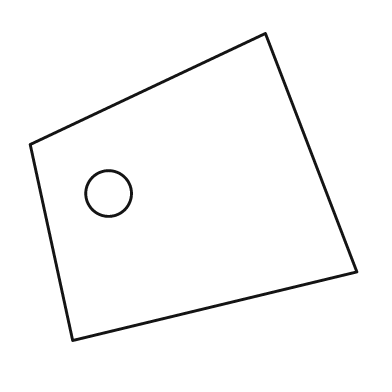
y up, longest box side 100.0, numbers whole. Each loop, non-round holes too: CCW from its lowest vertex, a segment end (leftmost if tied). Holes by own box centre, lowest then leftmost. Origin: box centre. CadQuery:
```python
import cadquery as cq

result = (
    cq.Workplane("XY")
    .moveTo(-37.0, -47.0)
    .lineTo(50.0, -26.0)
    .lineTo(22.0, 47.0)
    .lineTo(-50.0, 13.0)
    .close()
    .moveTo(-26.0, -2.0)
    .circle(7.0)
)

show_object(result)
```